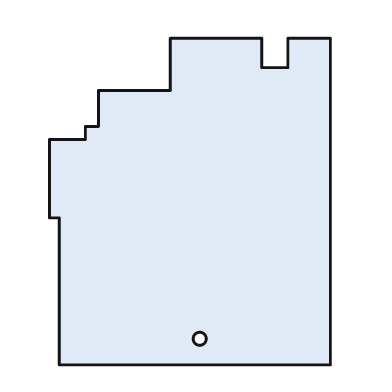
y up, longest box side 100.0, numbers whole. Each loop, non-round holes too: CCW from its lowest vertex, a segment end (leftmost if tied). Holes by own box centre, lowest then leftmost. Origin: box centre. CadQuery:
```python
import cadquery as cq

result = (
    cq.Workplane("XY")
    .moveTo(-40.0, -50.0)
    .lineTo(43.0, -50.0)
    .lineTo(43.0, 50.0)
    .lineTo(30.0, 50.0)
    .lineTo(30.0, 41.0)
    .lineTo(22.0, 41.0)
    .lineTo(22.0, 50.0)
    .lineTo(-6.0, 50.0)
    .lineTo(-6.0, 34.0)
    .lineTo(-28.0, 34.0)
    .lineTo(-28.0, 23.0)
    .lineTo(-32.0, 23.0)
    .lineTo(-32.0, 19.0)
    .lineTo(-43.0, 19.0)
    .lineTo(-43.0, -5.0)
    .lineTo(-40.0, -5.0)
    .close()
    .moveTo(3.0, -42.0)
    .circle(2.0)
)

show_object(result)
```